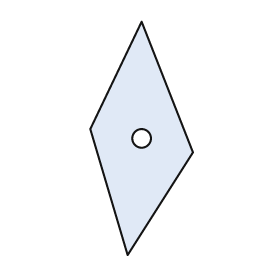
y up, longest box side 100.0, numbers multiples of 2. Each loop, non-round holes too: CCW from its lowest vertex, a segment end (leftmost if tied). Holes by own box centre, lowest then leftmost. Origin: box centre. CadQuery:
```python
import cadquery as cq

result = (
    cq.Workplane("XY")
    .moveTo(-6.0, -50.0)
    .lineTo(22.0, -6.0)
    .lineTo(0.0, 50.0)
    .lineTo(-22.0, 4.0)
    .close()
    .moveTo(0.0, 0.0)
    .circle(4.0)
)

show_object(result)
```